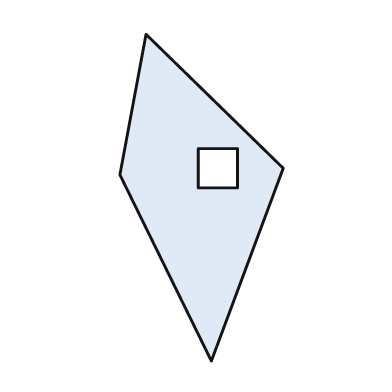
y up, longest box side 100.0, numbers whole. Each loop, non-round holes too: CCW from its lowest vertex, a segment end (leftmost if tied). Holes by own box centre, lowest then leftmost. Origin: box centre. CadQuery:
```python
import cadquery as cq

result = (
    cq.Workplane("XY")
    .moveTo(3.0, -50.0)
    .lineTo(25.0, 9.0)
    .lineTo(-17.0, 50.0)
    .lineTo(-25.0, 7.0)
    .close()
    .moveTo(-1.0, 3.0)
    .lineTo(11.0, 3.0)
    .lineTo(11.0, 15.0)
    .lineTo(-1.0, 15.0)
    .close()
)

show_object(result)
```